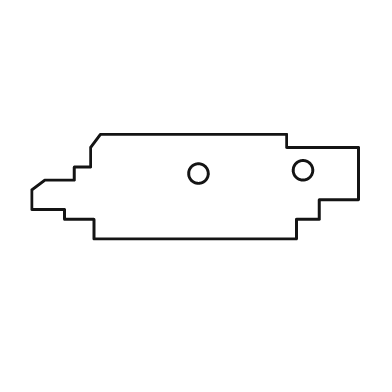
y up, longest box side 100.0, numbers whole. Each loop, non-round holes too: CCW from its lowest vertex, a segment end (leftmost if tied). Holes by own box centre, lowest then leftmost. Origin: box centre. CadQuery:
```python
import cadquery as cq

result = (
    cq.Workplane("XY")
    .moveTo(-31.0, -16.0)
    .lineTo(31.0, -16.0)
    .lineTo(31.0, -10.0)
    .lineTo(38.0, -10.0)
    .lineTo(38.0, -4.0)
    .lineTo(50.0, -4.0)
    .lineTo(50.0, 12.0)
    .lineTo(28.0, 12.0)
    .lineTo(28.0, 16.0)
    .lineTo(-29.0, 16.0)
    .lineTo(-32.0, 12.0)
    .lineTo(-32.0, 6.0)
    .lineTo(-37.0, 6.0)
    .lineTo(-37.0, 2.0)
    .lineTo(-46.0, 2.0)
    .lineTo(-50.0, -1.0)
    .lineTo(-50.0, -7.0)
    .lineTo(-40.0, -7.0)
    .lineTo(-40.0, -10.0)
    .lineTo(-31.0, -10.0)
    .close()
    .moveTo(1.0, 4.0)
    .circle(3.0)
    .moveTo(33.0, 5.0)
    .circle(3.0)
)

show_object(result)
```